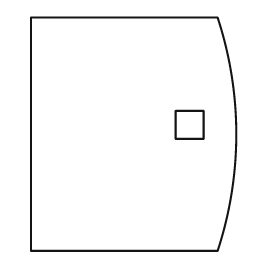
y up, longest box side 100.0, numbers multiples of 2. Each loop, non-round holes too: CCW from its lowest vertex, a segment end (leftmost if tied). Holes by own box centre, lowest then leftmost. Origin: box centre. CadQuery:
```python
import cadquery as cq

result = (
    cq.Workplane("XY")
    .moveTo(-44.0, -50.0)
    .lineTo(36.0, -50.0)
    .threePointArc((44.0, 0.0), (36.0, 50.0))
    .lineTo(-44.0, 50.0)
    .close()
    .moveTo(18.0, -2.0)
    .lineTo(30.0, -2.0)
    .lineTo(30.0, 10.0)
    .lineTo(18.0, 10.0)
    .close()
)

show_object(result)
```